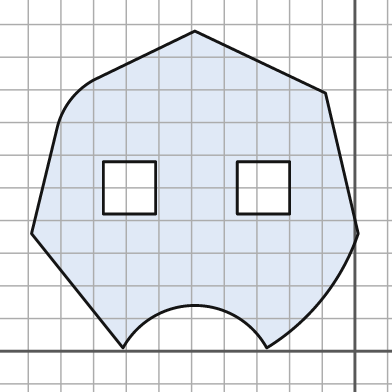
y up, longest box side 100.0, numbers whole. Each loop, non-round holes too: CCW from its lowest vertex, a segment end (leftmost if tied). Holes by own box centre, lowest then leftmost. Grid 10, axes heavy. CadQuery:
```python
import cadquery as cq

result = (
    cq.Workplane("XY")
    .moveTo(-71.0, 1.0)
    .threePointArc((-49.0, 14.0), (-27.0, 1.0))
    .threePointArc((-10.0, 16.0), (1.0, 36.0))
    .lineTo(-9.0, 79.0)
    .lineTo(-49.0, 98.0)
    .lineTo(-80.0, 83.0)
    .threePointArc((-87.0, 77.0), (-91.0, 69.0))
    .lineTo(-99.0, 36.0)
    .close()
    .moveTo(-77.0, 42.0)
    .lineTo(-61.0, 42.0)
    .lineTo(-61.0, 58.0)
    .lineTo(-77.0, 58.0)
    .close()
    .moveTo(-36.0, 42.0)
    .lineTo(-20.0, 42.0)
    .lineTo(-20.0, 58.0)
    .lineTo(-36.0, 58.0)
    .close()
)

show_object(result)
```